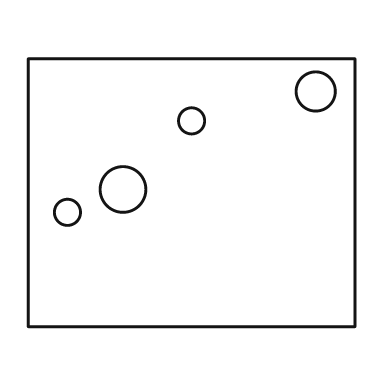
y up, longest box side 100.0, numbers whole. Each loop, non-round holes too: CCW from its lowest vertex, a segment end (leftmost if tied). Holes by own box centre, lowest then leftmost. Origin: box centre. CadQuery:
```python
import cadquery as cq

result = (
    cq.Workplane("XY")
    .moveTo(-50.0, -41.0)
    .lineTo(50.0, -41.0)
    .lineTo(50.0, 41.0)
    .lineTo(-50.0, 41.0)
    .close()
    .moveTo(-38.0, -6.0)
    .circle(4.0)
    .moveTo(-21.0, 1.0)
    .circle(7.0)
    .moveTo(0.0, 22.0)
    .circle(4.0)
    .moveTo(38.0, 31.0)
    .circle(6.0)
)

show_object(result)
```